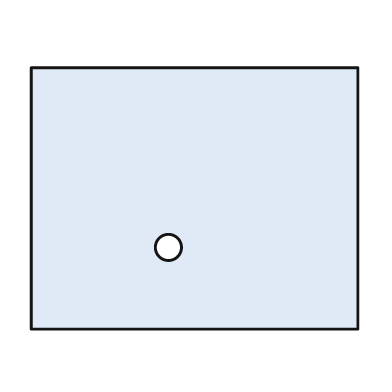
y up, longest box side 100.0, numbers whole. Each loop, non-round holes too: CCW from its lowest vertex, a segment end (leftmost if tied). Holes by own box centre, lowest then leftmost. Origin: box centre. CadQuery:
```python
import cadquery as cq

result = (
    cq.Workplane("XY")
    .moveTo(-50.0, -40.0)
    .lineTo(50.0, -40.0)
    .lineTo(50.0, 40.0)
    .lineTo(-50.0, 40.0)
    .close()
    .moveTo(-8.0, -15.0)
    .circle(4.0)
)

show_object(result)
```